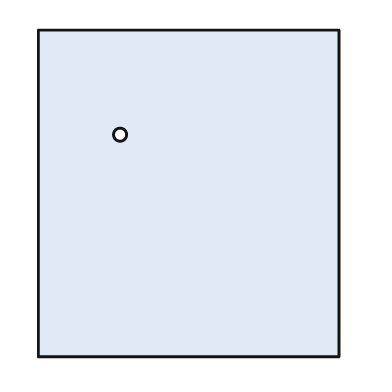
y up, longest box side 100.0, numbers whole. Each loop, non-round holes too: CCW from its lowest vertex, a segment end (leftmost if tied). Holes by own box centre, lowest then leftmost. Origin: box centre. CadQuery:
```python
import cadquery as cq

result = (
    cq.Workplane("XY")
    .moveTo(-46.0, -50.0)
    .lineTo(46.0, -50.0)
    .lineTo(46.0, 50.0)
    .lineTo(-46.0, 50.0)
    .close()
    .moveTo(-21.0, 18.0)
    .circle(2.0)
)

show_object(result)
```